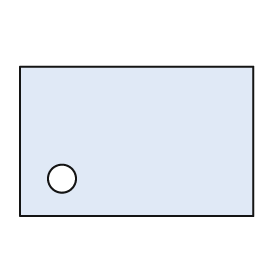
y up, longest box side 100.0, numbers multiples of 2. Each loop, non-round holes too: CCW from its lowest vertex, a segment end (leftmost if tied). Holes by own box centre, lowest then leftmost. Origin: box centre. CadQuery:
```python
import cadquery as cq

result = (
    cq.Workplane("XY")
    .moveTo(-50.0, -32.0)
    .lineTo(50.0, -32.0)
    .lineTo(50.0, 32.0)
    .lineTo(-50.0, 32.0)
    .close()
    .moveTo(-32.0, -16.0)
    .circle(6.0)
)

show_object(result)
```